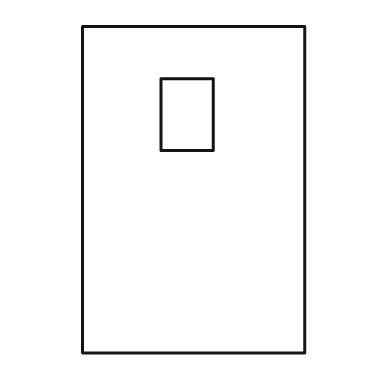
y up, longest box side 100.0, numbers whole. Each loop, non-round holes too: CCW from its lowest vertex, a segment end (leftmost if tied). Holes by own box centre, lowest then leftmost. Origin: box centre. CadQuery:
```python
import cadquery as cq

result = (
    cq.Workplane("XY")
    .moveTo(-34.0, -50.0)
    .lineTo(34.0, -50.0)
    .lineTo(34.0, 50.0)
    .lineTo(-34.0, 50.0)
    .close()
    .moveTo(-10.0, 12.0)
    .lineTo(6.0, 12.0)
    .lineTo(6.0, 34.0)
    .lineTo(-10.0, 34.0)
    .close()
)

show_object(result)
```